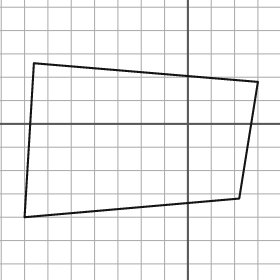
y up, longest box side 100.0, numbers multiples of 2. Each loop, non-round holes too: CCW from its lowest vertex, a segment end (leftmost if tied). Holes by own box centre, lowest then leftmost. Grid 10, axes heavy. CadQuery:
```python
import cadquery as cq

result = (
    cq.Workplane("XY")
    .moveTo(-70.0, -40.0)
    .lineTo(22.0, -32.0)
    .lineTo(30.0, 18.0)
    .lineTo(-66.0, 26.0)
    .close()
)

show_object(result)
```